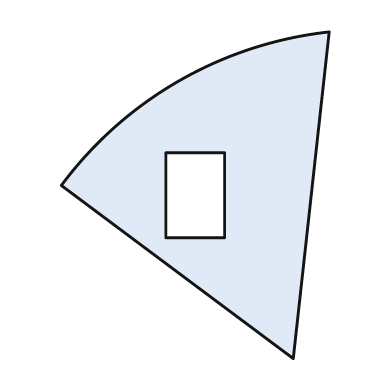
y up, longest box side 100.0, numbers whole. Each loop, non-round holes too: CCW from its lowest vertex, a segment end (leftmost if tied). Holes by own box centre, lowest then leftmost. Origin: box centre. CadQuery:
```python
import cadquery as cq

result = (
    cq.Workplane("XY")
    .moveTo(30.0, -50.0)
    .lineTo(41.0, 50.0)
    .threePointArc((-5.0, 35.0), (-41.0, 3.0))
    .close()
    .moveTo(-9.0, -13.0)
    .lineTo(9.0, -13.0)
    .lineTo(9.0, 13.0)
    .lineTo(-9.0, 13.0)
    .close()
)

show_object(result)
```